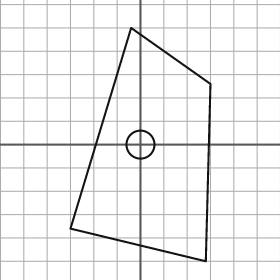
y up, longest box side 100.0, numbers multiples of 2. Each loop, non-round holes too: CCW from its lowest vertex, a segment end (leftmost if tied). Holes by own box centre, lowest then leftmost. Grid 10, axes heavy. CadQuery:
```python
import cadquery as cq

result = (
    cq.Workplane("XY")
    .moveTo(28.0, -50.0)
    .lineTo(30.0, 26.0)
    .lineTo(-4.0, 50.0)
    .lineTo(-30.0, -36.0)
    .close()
    .moveTo(0.0, 0.0)
    .circle(6.0)
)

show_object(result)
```